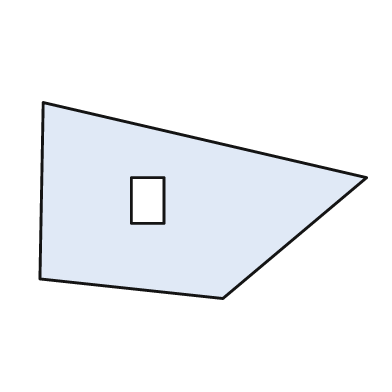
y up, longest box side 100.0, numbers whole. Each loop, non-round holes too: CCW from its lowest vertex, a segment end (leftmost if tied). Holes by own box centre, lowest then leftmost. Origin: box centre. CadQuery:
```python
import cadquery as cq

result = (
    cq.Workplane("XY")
    .moveTo(6.0, -30.0)
    .lineTo(50.0, 7.0)
    .lineTo(-49.0, 30.0)
    .lineTo(-50.0, -24.0)
    .close()
    .moveTo(-22.0, -7.0)
    .lineTo(-12.0, -7.0)
    .lineTo(-12.0, 7.0)
    .lineTo(-22.0, 7.0)
    .close()
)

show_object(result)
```